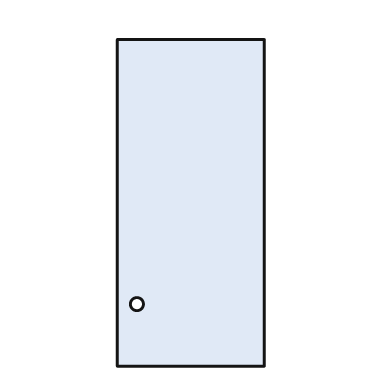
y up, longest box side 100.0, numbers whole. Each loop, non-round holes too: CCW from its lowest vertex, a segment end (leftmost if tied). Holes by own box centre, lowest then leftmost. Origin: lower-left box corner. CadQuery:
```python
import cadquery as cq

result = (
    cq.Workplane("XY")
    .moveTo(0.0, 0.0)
    .lineTo(45.0, 0.0)
    .lineTo(45.0, 100.0)
    .lineTo(0.0, 100.0)
    .close()
    .moveTo(6.0, 19.0)
    .circle(2.0)
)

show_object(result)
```